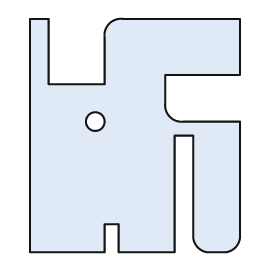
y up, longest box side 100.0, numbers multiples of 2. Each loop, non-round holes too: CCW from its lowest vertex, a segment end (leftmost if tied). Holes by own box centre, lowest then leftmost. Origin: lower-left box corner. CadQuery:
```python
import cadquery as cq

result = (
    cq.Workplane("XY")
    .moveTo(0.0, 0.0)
    .lineTo(32.0, 0.0)
    .lineTo(32.0, 12.0)
    .lineTo(38.0, 12.0)
    .lineTo(38.0, 0.0)
    .lineTo(62.0, 0.0)
    .lineTo(62.0, 50.0)
    .lineTo(70.0, 50.0)
    .lineTo(70.0, 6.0)
    .threePointArc((72.0, 2.0), (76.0, 0.0))
    .lineTo(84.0, 0.0)
    .threePointArc((88.0, 2.0), (90.0, 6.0))
    .lineTo(90.0, 56.0)
    .lineTo(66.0, 56.0)
    .threePointArc((60.0, 58.0), (58.0, 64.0))
    .lineTo(58.0, 76.0)
    .lineTo(90.0, 76.0)
    .lineTo(90.0, 100.0)
    .lineTo(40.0, 100.0)
    .threePointArc((34.0, 98.0), (32.0, 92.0))
    .lineTo(32.0, 72.0)
    .lineTo(8.0, 72.0)
    .lineTo(8.0, 100.0)
    .lineTo(0.0, 100.0)
    .close()
    .moveTo(28.0, 56.0)
    .circle(4.0)
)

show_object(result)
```